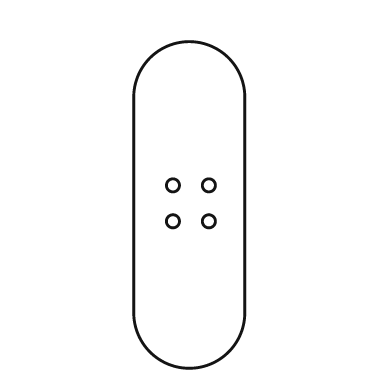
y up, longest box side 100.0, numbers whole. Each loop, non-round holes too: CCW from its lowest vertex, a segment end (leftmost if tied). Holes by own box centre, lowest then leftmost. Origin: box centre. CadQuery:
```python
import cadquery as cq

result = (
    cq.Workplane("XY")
    .moveTo(-17.0, -33.0)
    .threePointArc((0.0, -50.0), (17.0, -33.0))
    .lineTo(17.0, 33.0)
    .threePointArc((0.0, 50.0), (-17.0, 33.0))
    .close()
    .moveTo(-5.0, -5.0)
    .circle(2.0)
    .moveTo(6.0, -5.0)
    .circle(2.0)
    .moveTo(-5.0, 6.0)
    .circle(2.0)
    .moveTo(6.0, 6.0)
    .circle(2.0)
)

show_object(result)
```